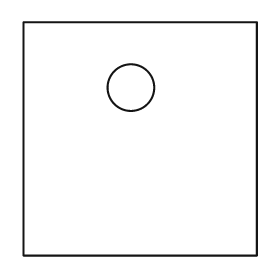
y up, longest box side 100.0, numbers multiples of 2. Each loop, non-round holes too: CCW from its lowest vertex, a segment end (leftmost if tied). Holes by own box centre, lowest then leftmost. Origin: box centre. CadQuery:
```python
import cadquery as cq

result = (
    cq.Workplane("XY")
    .moveTo(-50.0, -50.0)
    .lineTo(50.0, -50.0)
    .lineTo(50.0, 50.0)
    .lineTo(-50.0, 50.0)
    .close()
    .moveTo(-4.0, 22.0)
    .circle(10.0)
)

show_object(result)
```